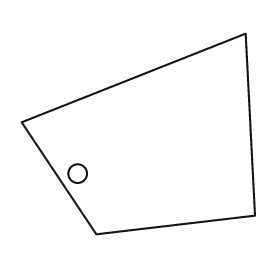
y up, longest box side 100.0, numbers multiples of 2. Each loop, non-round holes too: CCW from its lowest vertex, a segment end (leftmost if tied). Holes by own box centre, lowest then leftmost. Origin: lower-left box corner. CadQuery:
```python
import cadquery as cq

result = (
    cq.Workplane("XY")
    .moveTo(32.0, 0.0)
    .lineTo(100.0, 8.0)
    .lineTo(96.0, 86.0)
    .lineTo(0.0, 48.0)
    .close()
    .moveTo(24.0, 26.0)
    .circle(4.0)
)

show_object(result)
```